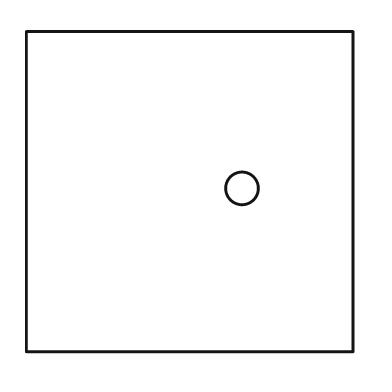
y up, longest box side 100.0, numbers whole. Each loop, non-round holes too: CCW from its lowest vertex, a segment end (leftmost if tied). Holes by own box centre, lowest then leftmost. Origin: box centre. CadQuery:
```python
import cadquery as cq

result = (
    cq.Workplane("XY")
    .moveTo(-50.0, -49.0)
    .lineTo(50.0, -49.0)
    .lineTo(50.0, 49.0)
    .lineTo(-50.0, 49.0)
    .close()
    .moveTo(16.0, 1.0)
    .circle(5.0)
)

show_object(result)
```